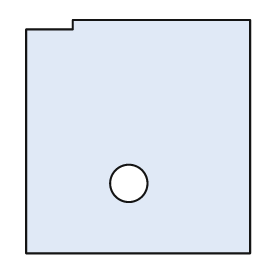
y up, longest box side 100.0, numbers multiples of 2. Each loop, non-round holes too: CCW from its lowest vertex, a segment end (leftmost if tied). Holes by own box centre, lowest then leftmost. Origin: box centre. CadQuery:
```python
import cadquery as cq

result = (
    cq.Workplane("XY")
    .moveTo(-48.0, -50.0)
    .lineTo(48.0, -50.0)
    .lineTo(48.0, 50.0)
    .lineTo(-28.0, 50.0)
    .lineTo(-28.0, 46.0)
    .lineTo(-48.0, 46.0)
    .close()
    .moveTo(-4.0, -20.0)
    .circle(8.0)
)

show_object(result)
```